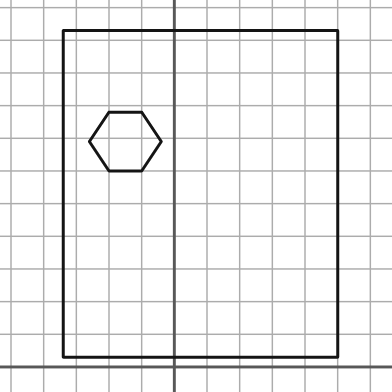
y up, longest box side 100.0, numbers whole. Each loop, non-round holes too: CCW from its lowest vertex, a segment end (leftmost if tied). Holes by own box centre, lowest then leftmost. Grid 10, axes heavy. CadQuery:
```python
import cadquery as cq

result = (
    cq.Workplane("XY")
    .moveTo(-34.0, 3.0)
    .lineTo(50.0, 3.0)
    .lineTo(50.0, 103.0)
    .lineTo(-34.0, 103.0)
    .close()
    .moveTo(-20.0, 60.0)
    .lineTo(-10.0, 60.0)
    .lineTo(-4.0, 69.0)
    .lineTo(-10.0, 78.0)
    .lineTo(-20.0, 78.0)
    .lineTo(-26.0, 69.0)
    .close()
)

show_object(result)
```